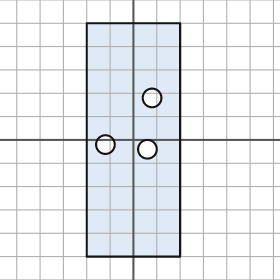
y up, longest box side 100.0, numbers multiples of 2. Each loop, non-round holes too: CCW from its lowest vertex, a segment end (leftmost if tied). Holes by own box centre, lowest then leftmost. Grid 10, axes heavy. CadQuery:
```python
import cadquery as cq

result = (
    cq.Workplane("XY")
    .moveTo(-20.0, -50.0)
    .lineTo(20.0, -50.0)
    .lineTo(20.0, 50.0)
    .lineTo(-20.0, 50.0)
    .close()
    .moveTo(6.0, -4.0)
    .circle(4.0)
    .moveTo(-12.0, -2.0)
    .circle(4.0)
    .moveTo(8.0, 18.0)
    .circle(4.0)
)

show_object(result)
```